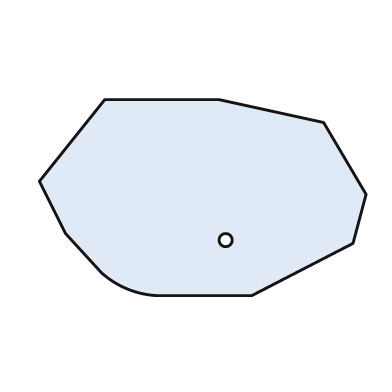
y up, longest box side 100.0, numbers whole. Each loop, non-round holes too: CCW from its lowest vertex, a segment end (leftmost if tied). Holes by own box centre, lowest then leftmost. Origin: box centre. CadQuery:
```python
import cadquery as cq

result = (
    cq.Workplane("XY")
    .moveTo(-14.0, -30.0)
    .lineTo(15.0, -30.0)
    .lineTo(46.0, -14.0)
    .lineTo(50.0, 1.0)
    .lineTo(37.0, 23.0)
    .lineTo(5.0, 30.0)
    .lineTo(-30.0, 30.0)
    .lineTo(-50.0, 5.0)
    .lineTo(-42.0, -11.0)
    .lineTo(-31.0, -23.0)
    .threePointArc((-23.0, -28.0), (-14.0, -30.0))
    .close()
    .moveTo(7.0, -13.0)
    .circle(2.0)
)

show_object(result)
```